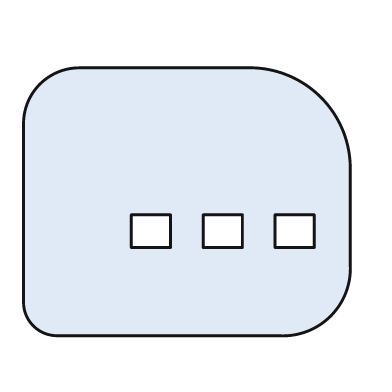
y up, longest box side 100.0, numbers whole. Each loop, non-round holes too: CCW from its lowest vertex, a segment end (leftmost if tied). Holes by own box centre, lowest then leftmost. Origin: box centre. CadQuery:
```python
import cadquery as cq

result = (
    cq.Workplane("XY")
    .moveTo(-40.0, -41.0)
    .lineTo(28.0, -41.0)
    .threePointArc((44.0, -35.0), (50.0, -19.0))
    .lineTo(50.0, 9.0)
    .threePointArc((41.0, 32.0), (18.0, 41.0))
    .lineTo(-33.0, 41.0)
    .threePointArc((-45.0, 36.0), (-50.0, 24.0))
    .lineTo(-50.0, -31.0)
    .threePointArc((-47.0, -38.0), (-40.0, -41.0))
    .close()
    .moveTo(-17.0, -14.0)
    .lineTo(-5.0, -14.0)
    .lineTo(-5.0, -4.0)
    .lineTo(-17.0, -4.0)
    .close()
    .moveTo(5.0, -14.0)
    .lineTo(17.0, -14.0)
    .lineTo(17.0, -4.0)
    .lineTo(5.0, -4.0)
    .close()
    .moveTo(27.0, -14.0)
    .lineTo(39.0, -14.0)
    .lineTo(39.0, -4.0)
    .lineTo(27.0, -4.0)
    .close()
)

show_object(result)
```